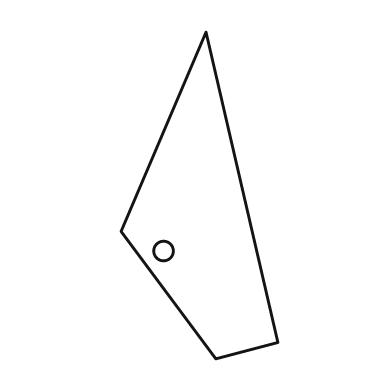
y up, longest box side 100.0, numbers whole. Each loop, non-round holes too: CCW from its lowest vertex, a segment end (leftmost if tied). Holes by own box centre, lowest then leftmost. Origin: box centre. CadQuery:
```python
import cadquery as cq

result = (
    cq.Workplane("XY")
    .moveTo(5.0, -50.0)
    .lineTo(24.0, -45.0)
    .lineTo(2.0, 50.0)
    .lineTo(-24.0, -11.0)
    .close()
    .moveTo(-11.0, -17.0)
    .circle(3.0)
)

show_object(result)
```